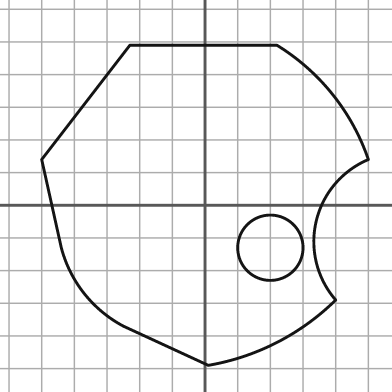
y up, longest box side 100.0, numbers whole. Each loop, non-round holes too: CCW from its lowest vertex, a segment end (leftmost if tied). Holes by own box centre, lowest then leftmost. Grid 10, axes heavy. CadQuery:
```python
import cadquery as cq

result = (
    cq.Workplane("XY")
    .moveTo(1.0, -49.0)
    .threePointArc((22.0, -42.0), (40.0, -29.0))
    .threePointArc((34.0, -5.0), (50.0, 14.0))
    .threePointArc((39.0, 34.0), (22.0, 49.0))
    .lineTo(-23.0, 49.0)
    .lineTo(-50.0, 14.0)
    .lineTo(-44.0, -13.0)
    .threePointArc((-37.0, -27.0), (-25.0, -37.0))
    .close()
    .moveTo(20.0, -13.0)
    .circle(10.0)
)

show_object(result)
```